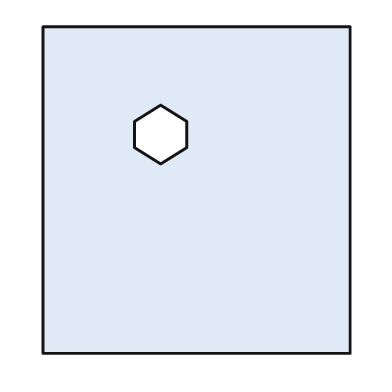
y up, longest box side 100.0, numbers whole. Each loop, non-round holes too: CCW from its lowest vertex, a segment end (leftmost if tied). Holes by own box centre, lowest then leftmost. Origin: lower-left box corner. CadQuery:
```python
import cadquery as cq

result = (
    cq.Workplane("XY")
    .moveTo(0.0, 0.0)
    .lineTo(94.0, 0.0)
    .lineTo(94.0, 100.0)
    .lineTo(0.0, 100.0)
    .close()
    .moveTo(36.0, 58.0)
    .lineTo(44.0, 63.0)
    .lineTo(44.0, 71.0)
    .lineTo(36.0, 76.0)
    .lineTo(28.0, 71.0)
    .lineTo(28.0, 63.0)
    .close()
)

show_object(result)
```